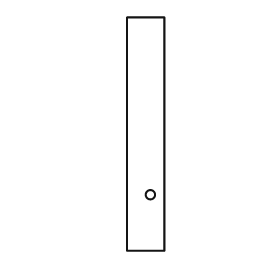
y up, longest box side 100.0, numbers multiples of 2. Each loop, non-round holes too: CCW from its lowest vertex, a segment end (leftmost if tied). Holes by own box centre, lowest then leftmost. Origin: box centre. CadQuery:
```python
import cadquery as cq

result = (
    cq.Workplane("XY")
    .moveTo(-8.0, -50.0)
    .lineTo(8.0, -50.0)
    .lineTo(8.0, 50.0)
    .lineTo(-8.0, 50.0)
    .close()
    .moveTo(2.0, -26.0)
    .circle(2.0)
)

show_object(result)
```